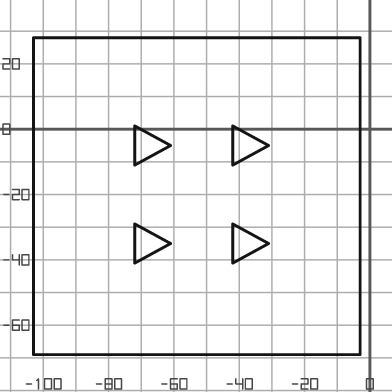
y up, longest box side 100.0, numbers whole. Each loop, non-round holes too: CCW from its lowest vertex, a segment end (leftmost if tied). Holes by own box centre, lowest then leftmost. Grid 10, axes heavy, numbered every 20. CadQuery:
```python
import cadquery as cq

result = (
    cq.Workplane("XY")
    .moveTo(-103.0, -69.0)
    .lineTo(-3.0, -69.0)
    .lineTo(-3.0, 28.0)
    .lineTo(-103.0, 28.0)
    .close()
    .moveTo(-72.0, -41.0)
    .lineTo(-61.0, -35.0)
    .lineTo(-72.0, -29.0)
    .close()
    .moveTo(-42.0, -41.0)
    .lineTo(-31.0, -35.0)
    .lineTo(-42.0, -29.0)
    .close()
    .moveTo(-72.0, -11.0)
    .lineTo(-61.0, -5.0)
    .lineTo(-72.0, 1.0)
    .close()
    .moveTo(-42.0, -11.0)
    .lineTo(-31.0, -5.0)
    .lineTo(-42.0, 1.0)
    .close()
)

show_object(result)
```